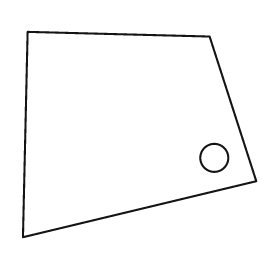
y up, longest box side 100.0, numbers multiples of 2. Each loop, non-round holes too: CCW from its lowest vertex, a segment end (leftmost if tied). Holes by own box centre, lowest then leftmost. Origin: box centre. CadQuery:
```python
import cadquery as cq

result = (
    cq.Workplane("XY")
    .moveTo(-50.0, -44.0)
    .lineTo(50.0, -20.0)
    .lineTo(30.0, 42.0)
    .lineTo(-48.0, 44.0)
    .close()
    .moveTo(32.0, -10.0)
    .circle(6.0)
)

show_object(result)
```